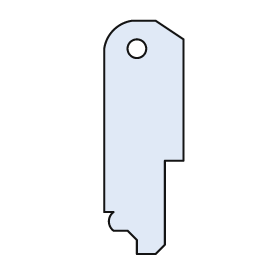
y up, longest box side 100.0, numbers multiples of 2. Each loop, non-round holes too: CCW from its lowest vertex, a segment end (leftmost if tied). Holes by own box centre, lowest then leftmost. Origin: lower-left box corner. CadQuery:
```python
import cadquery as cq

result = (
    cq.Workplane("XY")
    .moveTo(14.0, 0.0)
    .lineTo(22.0, 0.0)
    .lineTo(26.0, 4.0)
    .lineTo(26.0, 40.0)
    .lineTo(34.0, 40.0)
    .lineTo(34.0, 92.0)
    .lineTo(22.0, 100.0)
    .lineTo(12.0, 100.0)
    .threePointArc((4.0, 96.0), (0.0, 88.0))
    .lineTo(0.0, 18.0)
    .lineTo(4.0, 18.0)
    .threePointArc((2.0, 14.0), (4.0, 10.0))
    .lineTo(10.0, 10.0)
    .lineTo(14.0, 6.0)
    .close()
    .moveTo(14.0, 88.0)
    .circle(4.0)
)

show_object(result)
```